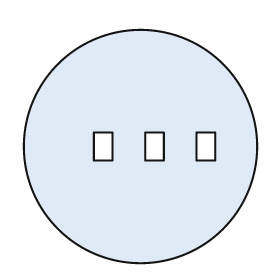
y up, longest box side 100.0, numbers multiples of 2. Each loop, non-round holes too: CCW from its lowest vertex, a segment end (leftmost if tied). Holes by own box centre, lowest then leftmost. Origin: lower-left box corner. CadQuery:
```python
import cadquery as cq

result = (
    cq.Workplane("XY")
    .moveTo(50.0, 50.0)
    .circle(50.0)
    .moveTo(30.0, 44.0)
    .lineTo(38.0, 44.0)
    .lineTo(38.0, 56.0)
    .lineTo(30.0, 56.0)
    .close()
    .moveTo(52.0, 44.0)
    .lineTo(60.0, 44.0)
    .lineTo(60.0, 56.0)
    .lineTo(52.0, 56.0)
    .close()
    .moveTo(74.0, 44.0)
    .lineTo(82.0, 44.0)
    .lineTo(82.0, 56.0)
    .lineTo(74.0, 56.0)
    .close()
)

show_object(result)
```